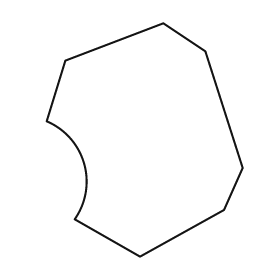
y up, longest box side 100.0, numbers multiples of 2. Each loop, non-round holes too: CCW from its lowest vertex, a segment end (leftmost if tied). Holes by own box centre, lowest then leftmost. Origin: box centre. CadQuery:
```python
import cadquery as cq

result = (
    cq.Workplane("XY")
    .moveTo(-2.0, -50.0)
    .lineTo(34.0, -30.0)
    .lineTo(42.0, -12.0)
    .lineTo(26.0, 38.0)
    .lineTo(8.0, 50.0)
    .lineTo(-34.0, 34.0)
    .lineTo(-42.0, 8.0)
    .threePointArc((-26.0, -10.0), (-30.0, -34.0))
    .close()
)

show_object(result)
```